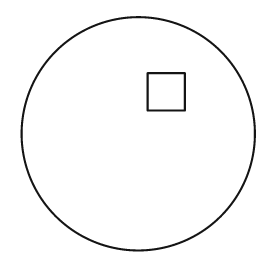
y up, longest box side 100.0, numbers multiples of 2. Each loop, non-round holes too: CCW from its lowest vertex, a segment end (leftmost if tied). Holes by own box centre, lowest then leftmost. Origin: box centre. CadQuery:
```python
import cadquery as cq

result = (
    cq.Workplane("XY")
    .moveTo(0.0, 0.0)
    .circle(50.0)
    .moveTo(4.0, 10.0)
    .lineTo(20.0, 10.0)
    .lineTo(20.0, 26.0)
    .lineTo(4.0, 26.0)
    .close()
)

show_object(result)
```